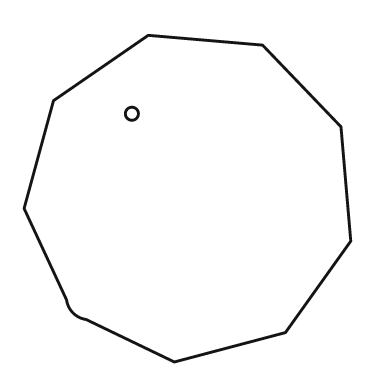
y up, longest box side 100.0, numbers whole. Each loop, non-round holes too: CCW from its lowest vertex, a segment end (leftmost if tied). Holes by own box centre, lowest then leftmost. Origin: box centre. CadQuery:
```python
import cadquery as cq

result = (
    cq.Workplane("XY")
    .moveTo(-4.0, -50.0)
    .lineTo(30.0, -41.0)
    .lineTo(50.0, -13.0)
    .lineTo(47.0, 22.0)
    .lineTo(23.0, 47.0)
    .lineTo(-12.0, 50.0)
    .lineTo(-41.0, 30.0)
    .lineTo(-50.0, -3.0)
    .lineTo(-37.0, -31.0)
    .threePointArc((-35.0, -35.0), (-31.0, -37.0))
    .close()
    .moveTo(-17.0, 26.0)
    .circle(2.0)
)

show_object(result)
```